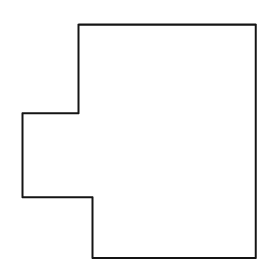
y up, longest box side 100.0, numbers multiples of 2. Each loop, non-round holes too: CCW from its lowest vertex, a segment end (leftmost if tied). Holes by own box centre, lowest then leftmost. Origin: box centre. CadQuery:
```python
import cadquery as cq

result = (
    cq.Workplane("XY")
    .moveTo(-20.0, -50.0)
    .lineTo(50.0, -50.0)
    .lineTo(50.0, 50.0)
    .lineTo(-26.0, 50.0)
    .lineTo(-26.0, 12.0)
    .lineTo(-50.0, 12.0)
    .lineTo(-50.0, -24.0)
    .lineTo(-20.0, -24.0)
    .close()
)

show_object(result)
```